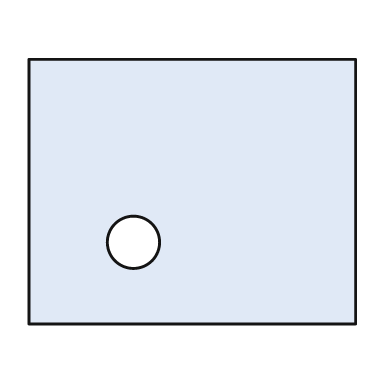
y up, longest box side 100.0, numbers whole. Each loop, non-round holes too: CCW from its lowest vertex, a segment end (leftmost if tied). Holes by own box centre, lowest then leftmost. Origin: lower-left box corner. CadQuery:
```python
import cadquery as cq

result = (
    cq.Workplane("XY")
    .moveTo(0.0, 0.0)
    .lineTo(100.0, 0.0)
    .lineTo(100.0, 81.0)
    .lineTo(0.0, 81.0)
    .close()
    .moveTo(32.0, 25.0)
    .circle(8.0)
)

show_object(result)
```